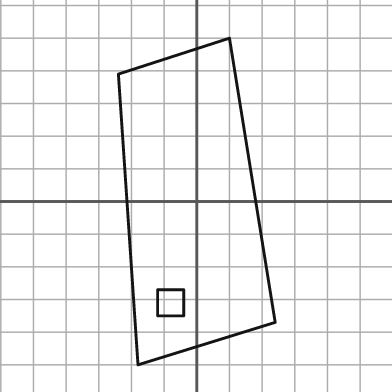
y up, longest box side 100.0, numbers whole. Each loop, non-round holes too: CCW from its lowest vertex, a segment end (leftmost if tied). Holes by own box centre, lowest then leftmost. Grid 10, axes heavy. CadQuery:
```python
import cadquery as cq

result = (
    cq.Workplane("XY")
    .moveTo(-18.0, -50.0)
    .lineTo(24.0, -37.0)
    .lineTo(10.0, 50.0)
    .lineTo(-24.0, 39.0)
    .close()
    .moveTo(-12.0, -35.0)
    .lineTo(-4.0, -35.0)
    .lineTo(-4.0, -27.0)
    .lineTo(-12.0, -27.0)
    .close()
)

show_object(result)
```